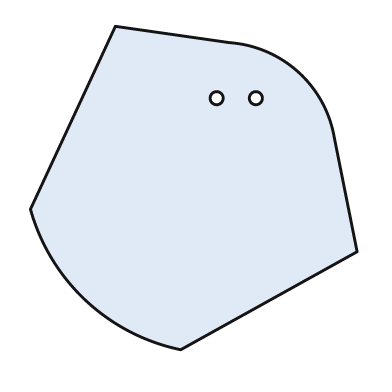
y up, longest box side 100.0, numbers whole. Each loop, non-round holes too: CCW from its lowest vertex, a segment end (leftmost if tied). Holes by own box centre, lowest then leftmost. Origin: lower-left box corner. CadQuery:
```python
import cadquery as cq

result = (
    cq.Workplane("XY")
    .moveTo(46.0, 0.0)
    .lineTo(100.0, 30.0)
    .lineTo(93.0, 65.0)
    .threePointArc((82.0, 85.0), (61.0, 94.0))
    .lineTo(26.0, 99.0)
    .lineTo(0.0, 43.0)
    .threePointArc((17.0, 15.0), (46.0, 0.0))
    .close()
    .moveTo(57.0, 77.0)
    .circle(2.0)
    .moveTo(69.0, 77.0)
    .circle(2.0)
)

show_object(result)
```